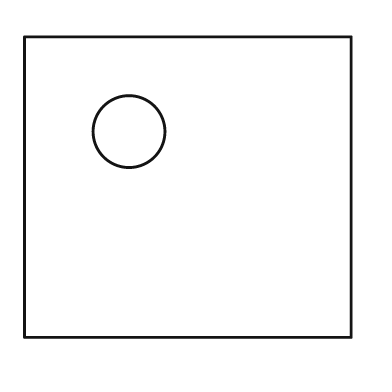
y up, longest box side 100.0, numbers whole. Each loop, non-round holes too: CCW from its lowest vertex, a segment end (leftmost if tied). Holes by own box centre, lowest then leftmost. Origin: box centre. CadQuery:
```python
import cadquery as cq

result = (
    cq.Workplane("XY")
    .moveTo(-50.0, -46.0)
    .lineTo(50.0, -46.0)
    .lineTo(50.0, 46.0)
    .lineTo(-50.0, 46.0)
    .close()
    .moveTo(-18.0, 17.0)
    .circle(11.0)
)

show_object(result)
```